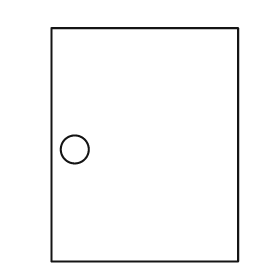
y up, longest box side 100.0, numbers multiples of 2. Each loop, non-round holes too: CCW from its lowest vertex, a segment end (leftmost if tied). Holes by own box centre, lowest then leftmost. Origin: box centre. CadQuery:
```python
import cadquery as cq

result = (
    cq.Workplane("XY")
    .moveTo(-40.0, -50.0)
    .lineTo(40.0, -50.0)
    .lineTo(40.0, 50.0)
    .lineTo(-40.0, 50.0)
    .close()
    .moveTo(-30.0, -2.0)
    .circle(6.0)
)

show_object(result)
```